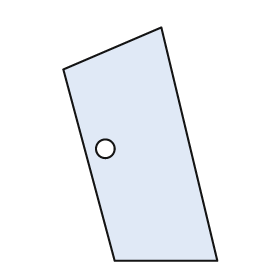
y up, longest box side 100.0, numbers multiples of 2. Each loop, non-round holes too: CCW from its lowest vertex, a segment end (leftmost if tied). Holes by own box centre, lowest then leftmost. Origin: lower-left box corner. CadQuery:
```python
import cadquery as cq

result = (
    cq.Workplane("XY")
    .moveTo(22.0, 0.0)
    .lineTo(66.0, 0.0)
    .lineTo(42.0, 100.0)
    .lineTo(0.0, 82.0)
    .close()
    .moveTo(18.0, 48.0)
    .circle(4.0)
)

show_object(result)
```